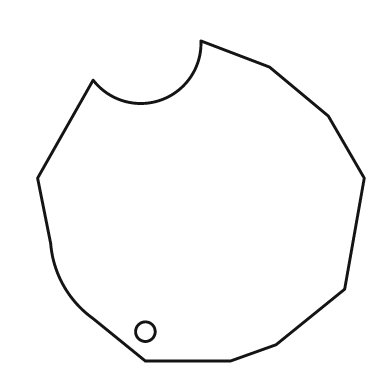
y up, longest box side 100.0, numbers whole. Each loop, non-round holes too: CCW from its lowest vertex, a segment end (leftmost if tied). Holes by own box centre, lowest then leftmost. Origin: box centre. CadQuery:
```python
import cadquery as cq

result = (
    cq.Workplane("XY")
    .moveTo(-17.0, -49.0)
    .lineTo(9.0, -49.0)
    .lineTo(23.0, -44.0)
    .lineTo(44.0, -27.0)
    .lineTo(50.0, 7.0)
    .lineTo(39.0, 26.0)
    .lineTo(21.0, 41.0)
    .lineTo(0.0, 49.0)
    .threePointArc((-12.0, 31.0), (-33.0, 37.0))
    .lineTo(-50.0, 7.0)
    .lineTo(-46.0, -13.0)
    .threePointArc((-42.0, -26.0), (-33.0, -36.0))
    .close()
    .moveTo(-17.0, -40.0)
    .circle(3.0)
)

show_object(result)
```